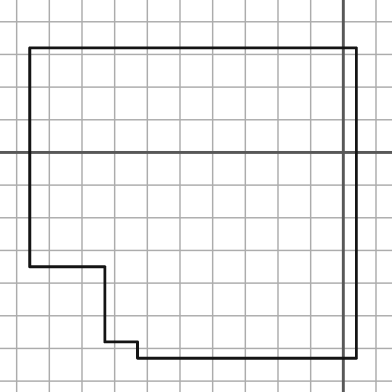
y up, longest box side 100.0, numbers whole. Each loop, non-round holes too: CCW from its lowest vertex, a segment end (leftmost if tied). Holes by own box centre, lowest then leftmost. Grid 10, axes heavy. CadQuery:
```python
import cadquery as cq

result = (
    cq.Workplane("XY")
    .moveTo(-63.0, -63.0)
    .lineTo(4.0, -63.0)
    .lineTo(4.0, 32.0)
    .lineTo(-96.0, 32.0)
    .lineTo(-96.0, -35.0)
    .lineTo(-73.0, -35.0)
    .lineTo(-73.0, -58.0)
    .lineTo(-63.0, -58.0)
    .close()
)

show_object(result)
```